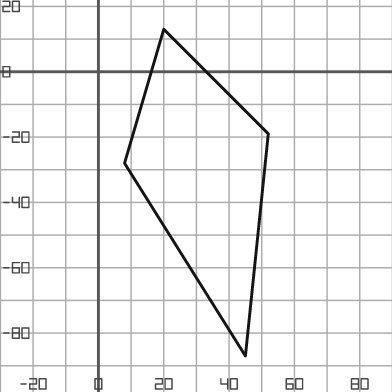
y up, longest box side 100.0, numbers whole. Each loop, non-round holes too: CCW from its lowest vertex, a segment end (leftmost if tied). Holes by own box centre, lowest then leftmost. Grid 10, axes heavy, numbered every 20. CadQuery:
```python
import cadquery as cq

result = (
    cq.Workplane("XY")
    .moveTo(45.0, -87.0)
    .lineTo(52.0, -19.0)
    .lineTo(20.0, 13.0)
    .lineTo(8.0, -28.0)
    .close()
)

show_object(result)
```